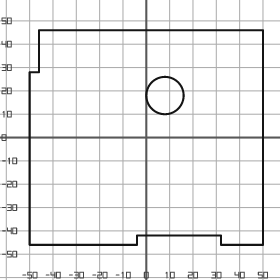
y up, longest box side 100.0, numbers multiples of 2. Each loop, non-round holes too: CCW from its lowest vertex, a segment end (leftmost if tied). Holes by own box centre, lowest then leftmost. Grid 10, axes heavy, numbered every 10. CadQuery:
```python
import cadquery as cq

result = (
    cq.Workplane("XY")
    .moveTo(-50.0, -46.0)
    .lineTo(-4.0, -46.0)
    .lineTo(-4.0, -42.0)
    .lineTo(32.0, -42.0)
    .lineTo(32.0, -46.0)
    .lineTo(50.0, -46.0)
    .lineTo(50.0, 46.0)
    .lineTo(-46.0, 46.0)
    .lineTo(-46.0, 28.0)
    .lineTo(-50.0, 28.0)
    .close()
    .moveTo(8.0, 18.0)
    .circle(8.0)
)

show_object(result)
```